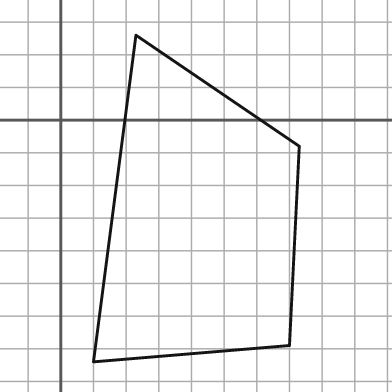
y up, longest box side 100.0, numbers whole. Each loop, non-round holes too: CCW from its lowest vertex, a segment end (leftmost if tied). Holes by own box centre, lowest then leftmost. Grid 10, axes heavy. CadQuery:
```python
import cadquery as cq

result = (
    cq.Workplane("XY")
    .moveTo(10.0, -74.0)
    .lineTo(70.0, -69.0)
    .lineTo(73.0, -8.0)
    .lineTo(23.0, 26.0)
    .close()
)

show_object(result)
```